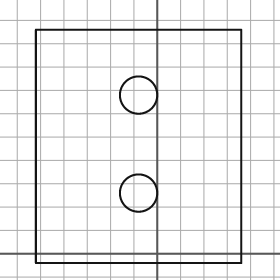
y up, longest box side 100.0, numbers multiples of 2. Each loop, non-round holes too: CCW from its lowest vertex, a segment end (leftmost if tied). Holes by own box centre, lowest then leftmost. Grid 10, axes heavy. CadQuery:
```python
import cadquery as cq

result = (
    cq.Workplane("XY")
    .moveTo(-52.0, -4.0)
    .lineTo(36.0, -4.0)
    .lineTo(36.0, 96.0)
    .lineTo(-52.0, 96.0)
    .close()
    .moveTo(-8.0, 26.0)
    .circle(8.0)
    .moveTo(-8.0, 68.0)
    .circle(8.0)
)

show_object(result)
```